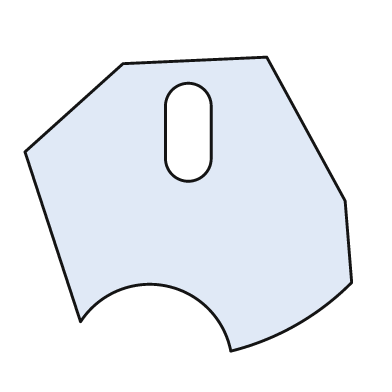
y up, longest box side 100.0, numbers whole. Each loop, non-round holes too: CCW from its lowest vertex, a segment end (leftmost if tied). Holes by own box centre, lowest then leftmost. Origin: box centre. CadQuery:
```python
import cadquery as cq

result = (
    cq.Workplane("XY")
    .moveTo(13.0, -45.0)
    .threePointArc((33.0, -37.0), (50.0, -24.0))
    .lineTo(48.0, 1.0)
    .lineTo(24.0, 45.0)
    .lineTo(-20.0, 43.0)
    .lineTo(-50.0, 16.0)
    .lineTo(-33.0, -36.0)
    .threePointArc((-7.0, -25.0), (13.0, -45.0))
    .close()
    .moveTo(-7.0, 14.0)
    .threePointArc((0.0, 7.0), (7.0, 14.0))
    .lineTo(7.0, 30.0)
    .threePointArc((0.0, 37.0), (-7.0, 30.0))
    .close()
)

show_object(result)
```